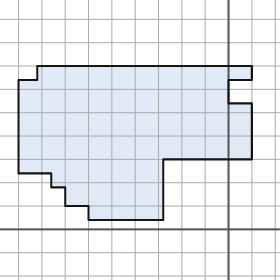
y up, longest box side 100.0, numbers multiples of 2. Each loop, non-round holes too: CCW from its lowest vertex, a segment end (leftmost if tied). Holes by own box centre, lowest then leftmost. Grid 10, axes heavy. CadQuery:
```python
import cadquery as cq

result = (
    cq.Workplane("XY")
    .moveTo(-60.0, 4.0)
    .lineTo(-28.0, 4.0)
    .lineTo(-28.0, 30.0)
    .lineTo(10.0, 30.0)
    .lineTo(10.0, 54.0)
    .lineTo(0.0, 54.0)
    .lineTo(0.0, 64.0)
    .lineTo(10.0, 64.0)
    .lineTo(10.0, 70.0)
    .lineTo(-82.0, 70.0)
    .lineTo(-82.0, 64.0)
    .lineTo(-90.0, 64.0)
    .lineTo(-90.0, 24.0)
    .lineTo(-76.0, 24.0)
    .lineTo(-76.0, 18.0)
    .lineTo(-70.0, 18.0)
    .lineTo(-70.0, 10.0)
    .lineTo(-60.0, 10.0)
    .close()
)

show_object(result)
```